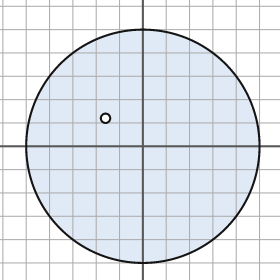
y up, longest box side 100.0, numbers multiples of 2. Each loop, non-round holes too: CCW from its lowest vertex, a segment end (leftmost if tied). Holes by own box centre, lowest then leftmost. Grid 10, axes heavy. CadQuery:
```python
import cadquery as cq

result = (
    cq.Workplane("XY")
    .moveTo(0.0, 0.0)
    .circle(50.0)
    .moveTo(-16.0, 12.0)
    .circle(2.0)
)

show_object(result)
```